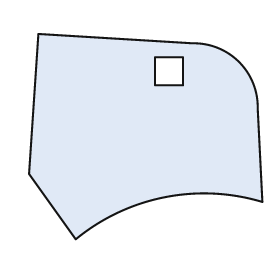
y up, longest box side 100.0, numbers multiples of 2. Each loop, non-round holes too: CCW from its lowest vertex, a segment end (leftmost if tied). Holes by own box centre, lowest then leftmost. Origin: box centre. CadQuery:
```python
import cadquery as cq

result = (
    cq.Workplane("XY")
    .moveTo(-30.0, -44.0)
    .threePointArc((8.0, -26.0), (50.0, -28.0))
    .lineTo(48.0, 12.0)
    .threePointArc((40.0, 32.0), (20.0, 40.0))
    .lineTo(-46.0, 44.0)
    .lineTo(-50.0, -16.0)
    .close()
    .moveTo(4.0, 22.0)
    .lineTo(16.0, 22.0)
    .lineTo(16.0, 34.0)
    .lineTo(4.0, 34.0)
    .close()
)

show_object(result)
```